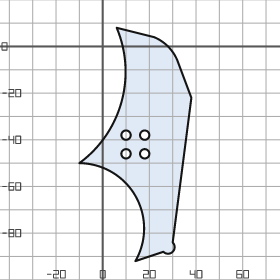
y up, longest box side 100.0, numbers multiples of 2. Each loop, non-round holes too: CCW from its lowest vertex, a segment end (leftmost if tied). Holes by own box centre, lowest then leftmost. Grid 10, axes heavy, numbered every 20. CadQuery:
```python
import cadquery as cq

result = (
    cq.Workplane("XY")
    .moveTo(14.0, -92.0)
    .lineTo(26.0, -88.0)
    .threePointArc((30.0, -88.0), (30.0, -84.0))
    .lineTo(38.0, -22.0)
    .lineTo(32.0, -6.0)
    .threePointArc((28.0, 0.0), (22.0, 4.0))
    .lineTo(6.0, 8.0)
    .threePointArc((8.0, -24.0), (-10.0, -50.0))
    .threePointArc((14.0, -64.0), (14.0, -92.0))
    .close()
    .moveTo(10.0, -46.0)
    .circle(2.0)
    .moveTo(18.0, -46.0)
    .circle(2.0)
    .moveTo(10.0, -38.0)
    .circle(2.0)
    .moveTo(18.0, -38.0)
    .circle(2.0)
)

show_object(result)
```